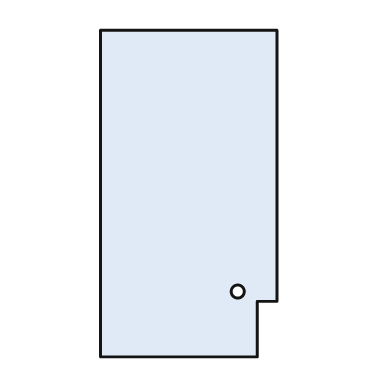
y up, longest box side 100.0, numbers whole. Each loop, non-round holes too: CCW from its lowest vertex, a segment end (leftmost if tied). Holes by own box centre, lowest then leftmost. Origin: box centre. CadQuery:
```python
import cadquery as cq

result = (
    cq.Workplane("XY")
    .moveTo(-27.0, -50.0)
    .lineTo(21.0, -50.0)
    .lineTo(21.0, -33.0)
    .lineTo(27.0, -33.0)
    .lineTo(27.0, 50.0)
    .lineTo(-27.0, 50.0)
    .close()
    .moveTo(15.0, -30.0)
    .circle(2.0)
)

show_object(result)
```